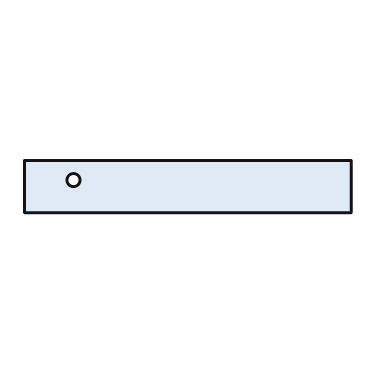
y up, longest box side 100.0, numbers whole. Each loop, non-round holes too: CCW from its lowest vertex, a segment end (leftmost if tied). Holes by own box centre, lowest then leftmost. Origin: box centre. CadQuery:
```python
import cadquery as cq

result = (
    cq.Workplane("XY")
    .moveTo(-50.0, -8.0)
    .lineTo(50.0, -8.0)
    .lineTo(50.0, 8.0)
    .lineTo(-50.0, 8.0)
    .close()
    .moveTo(-35.0, 2.0)
    .circle(2.0)
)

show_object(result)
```